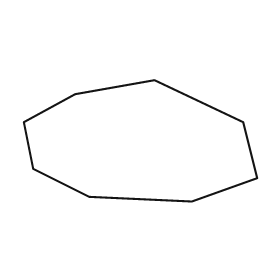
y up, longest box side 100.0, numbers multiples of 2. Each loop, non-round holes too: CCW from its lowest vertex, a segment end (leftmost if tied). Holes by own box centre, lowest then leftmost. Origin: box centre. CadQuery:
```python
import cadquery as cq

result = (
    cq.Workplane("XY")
    .moveTo(22.0, -26.0)
    .lineTo(50.0, -16.0)
    .lineTo(44.0, 8.0)
    .lineTo(6.0, 26.0)
    .lineTo(-28.0, 20.0)
    .lineTo(-50.0, 8.0)
    .lineTo(-46.0, -12.0)
    .lineTo(-22.0, -24.0)
    .close()
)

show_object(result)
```